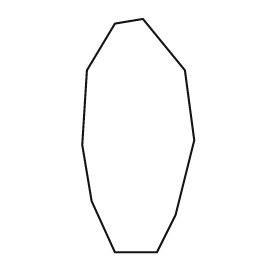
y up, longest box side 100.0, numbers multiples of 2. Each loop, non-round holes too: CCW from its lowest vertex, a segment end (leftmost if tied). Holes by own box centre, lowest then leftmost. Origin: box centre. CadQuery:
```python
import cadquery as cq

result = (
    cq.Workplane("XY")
    .moveTo(-10.0, -50.0)
    .lineTo(8.0, -50.0)
    .lineTo(16.0, -34.0)
    .lineTo(24.0, -2.0)
    .lineTo(20.0, 28.0)
    .lineTo(2.0, 50.0)
    .lineTo(-10.0, 48.0)
    .lineTo(-22.0, 28.0)
    .lineTo(-24.0, -4.0)
    .lineTo(-20.0, -28.0)
    .close()
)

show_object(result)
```